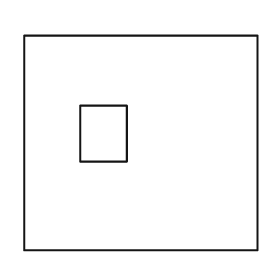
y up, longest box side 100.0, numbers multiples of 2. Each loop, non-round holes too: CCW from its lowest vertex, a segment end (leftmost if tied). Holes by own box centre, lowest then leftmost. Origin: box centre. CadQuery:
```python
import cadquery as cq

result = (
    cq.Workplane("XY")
    .moveTo(-50.0, -46.0)
    .lineTo(50.0, -46.0)
    .lineTo(50.0, 46.0)
    .lineTo(-50.0, 46.0)
    .close()
    .moveTo(-26.0, -8.0)
    .lineTo(-6.0, -8.0)
    .lineTo(-6.0, 16.0)
    .lineTo(-26.0, 16.0)
    .close()
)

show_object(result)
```